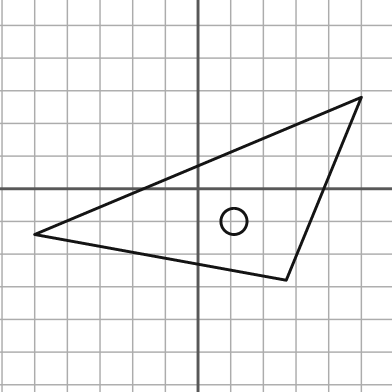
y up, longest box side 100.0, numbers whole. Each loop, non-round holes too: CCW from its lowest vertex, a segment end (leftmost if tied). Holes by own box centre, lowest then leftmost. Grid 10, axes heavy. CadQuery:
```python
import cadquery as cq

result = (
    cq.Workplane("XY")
    .moveTo(27.0, -28.0)
    .lineTo(50.0, 28.0)
    .lineTo(-50.0, -14.0)
    .close()
    .moveTo(11.0, -10.0)
    .circle(4.0)
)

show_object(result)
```